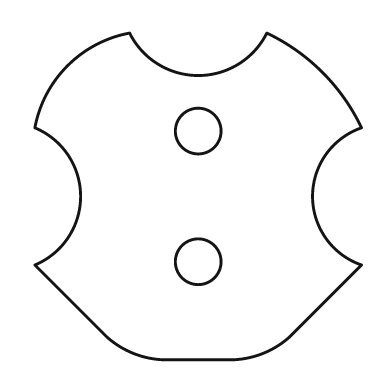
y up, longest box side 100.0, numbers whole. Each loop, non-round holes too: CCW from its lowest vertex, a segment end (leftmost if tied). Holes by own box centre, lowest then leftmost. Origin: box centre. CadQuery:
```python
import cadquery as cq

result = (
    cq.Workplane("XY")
    .moveTo(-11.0, -50.0)
    .lineTo(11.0, -50.0)
    .threePointArc((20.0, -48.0), (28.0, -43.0))
    .lineTo(50.0, -21.0)
    .threePointArc((35.0, 0.0), (50.0, 21.0))
    .threePointArc((38.0, 38.0), (21.0, 50.0))
    .threePointArc((0.0, 37.0), (-21.0, 50.0))
    .threePointArc((-40.0, 40.0), (-50.0, 21.0))
    .threePointArc((-36.0, 0.0), (-50.0, -21.0))
    .lineTo(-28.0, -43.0)
    .threePointArc((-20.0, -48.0), (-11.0, -50.0))
    .close()
    .moveTo(0.0, -20.0)
    .circle(7.0)
    .moveTo(0.0, 20.0)
    .circle(7.0)
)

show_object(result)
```